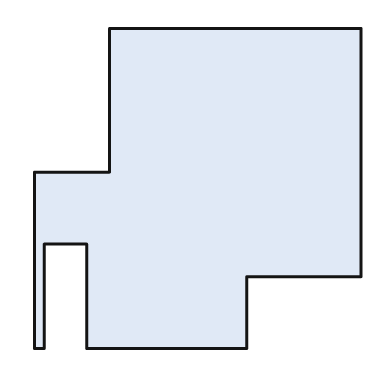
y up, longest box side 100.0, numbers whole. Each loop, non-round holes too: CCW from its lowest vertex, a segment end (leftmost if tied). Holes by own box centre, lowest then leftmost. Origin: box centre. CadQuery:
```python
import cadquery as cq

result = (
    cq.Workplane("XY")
    .moveTo(-50.0, -49.0)
    .lineTo(-47.0, -49.0)
    .lineTo(-47.0, -17.0)
    .lineTo(-34.0, -17.0)
    .lineTo(-34.0, -49.0)
    .lineTo(15.0, -49.0)
    .lineTo(15.0, -27.0)
    .lineTo(50.0, -27.0)
    .lineTo(50.0, 49.0)
    .lineTo(-27.0, 49.0)
    .lineTo(-27.0, 5.0)
    .lineTo(-50.0, 5.0)
    .close()
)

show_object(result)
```